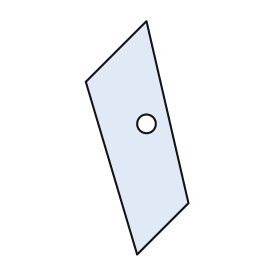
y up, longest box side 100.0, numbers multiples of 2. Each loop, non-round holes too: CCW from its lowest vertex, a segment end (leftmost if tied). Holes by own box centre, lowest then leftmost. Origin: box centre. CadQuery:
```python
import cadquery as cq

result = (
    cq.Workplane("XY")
    .moveTo(0.0, -50.0)
    .lineTo(22.0, -28.0)
    .lineTo(4.0, 50.0)
    .lineTo(-22.0, 24.0)
    .close()
    .moveTo(4.0, 6.0)
    .circle(4.0)
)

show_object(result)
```